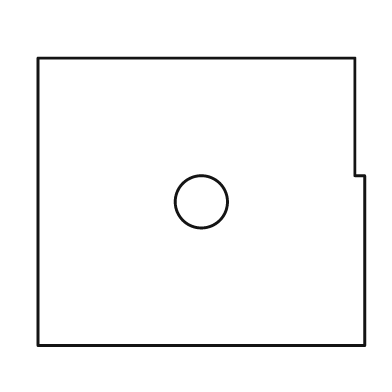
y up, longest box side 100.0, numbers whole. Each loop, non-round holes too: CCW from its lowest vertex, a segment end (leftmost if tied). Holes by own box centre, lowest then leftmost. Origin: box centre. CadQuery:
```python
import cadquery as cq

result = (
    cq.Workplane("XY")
    .moveTo(-50.0, -44.0)
    .lineTo(50.0, -44.0)
    .lineTo(50.0, 8.0)
    .lineTo(47.0, 8.0)
    .lineTo(47.0, 44.0)
    .lineTo(-50.0, 44.0)
    .close()
    .moveTo(0.0, 0.0)
    .circle(8.0)
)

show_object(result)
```